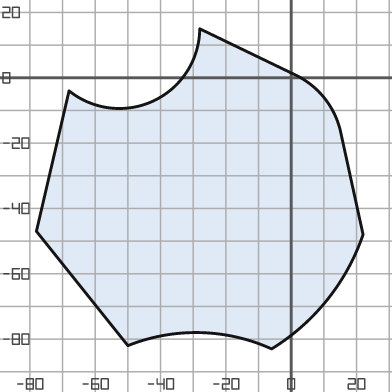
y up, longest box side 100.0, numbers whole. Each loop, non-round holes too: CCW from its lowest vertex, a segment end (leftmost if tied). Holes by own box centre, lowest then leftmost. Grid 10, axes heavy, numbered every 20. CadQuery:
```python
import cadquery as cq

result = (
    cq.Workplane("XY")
    .moveTo(-6.0, -83.0)
    .threePointArc((11.0, -68.0), (22.0, -48.0))
    .lineTo(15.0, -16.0)
    .threePointArc((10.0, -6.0), (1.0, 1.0))
    .lineTo(-28.0, 15.0)
    .threePointArc((-42.0, -7.0), (-68.0, -4.0))
    .lineTo(-78.0, -47.0)
    .lineTo(-50.0, -82.0)
    .threePointArc((-28.0, -78.0), (-6.0, -83.0))
    .close()
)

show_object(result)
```